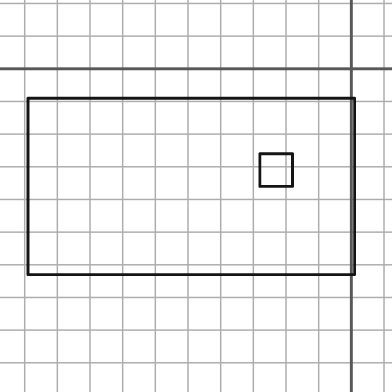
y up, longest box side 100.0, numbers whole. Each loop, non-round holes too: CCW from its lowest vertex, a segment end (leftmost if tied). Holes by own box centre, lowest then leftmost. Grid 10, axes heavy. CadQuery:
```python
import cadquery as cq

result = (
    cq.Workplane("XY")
    .moveTo(-99.0, -63.0)
    .lineTo(1.0, -63.0)
    .lineTo(1.0, -9.0)
    .lineTo(-99.0, -9.0)
    .close()
    .moveTo(-28.0, -36.0)
    .lineTo(-18.0, -36.0)
    .lineTo(-18.0, -26.0)
    .lineTo(-28.0, -26.0)
    .close()
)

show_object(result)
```